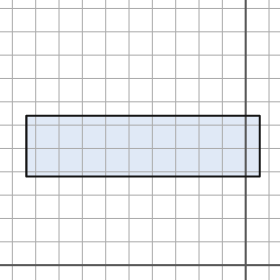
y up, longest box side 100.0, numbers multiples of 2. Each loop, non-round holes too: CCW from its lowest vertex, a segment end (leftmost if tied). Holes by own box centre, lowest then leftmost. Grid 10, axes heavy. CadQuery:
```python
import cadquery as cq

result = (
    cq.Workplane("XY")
    .moveTo(-94.0, 38.0)
    .lineTo(6.0, 38.0)
    .lineTo(6.0, 64.0)
    .lineTo(-94.0, 64.0)
    .close()
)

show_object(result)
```